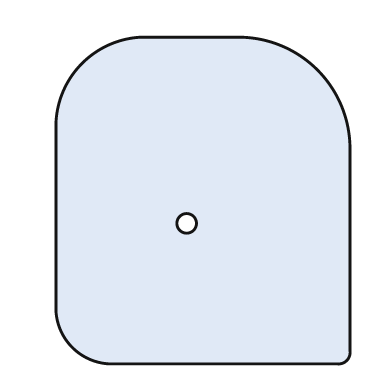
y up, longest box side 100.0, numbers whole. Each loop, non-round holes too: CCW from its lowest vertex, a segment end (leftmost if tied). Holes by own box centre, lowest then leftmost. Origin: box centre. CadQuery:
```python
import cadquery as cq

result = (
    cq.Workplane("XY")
    .moveTo(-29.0, -50.0)
    .lineTo(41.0, -50.0)
    .threePointArc((44.0, -49.0), (45.0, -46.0))
    .lineTo(45.0, 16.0)
    .threePointArc((35.0, 40.0), (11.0, 50.0))
    .lineTo(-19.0, 50.0)
    .threePointArc((-37.0, 42.0), (-45.0, 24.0))
    .lineTo(-45.0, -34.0)
    .threePointArc((-40.0, -45.0), (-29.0, -50.0))
    .close()
    .moveTo(-5.0, -7.0)
    .circle(3.0)
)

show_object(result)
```